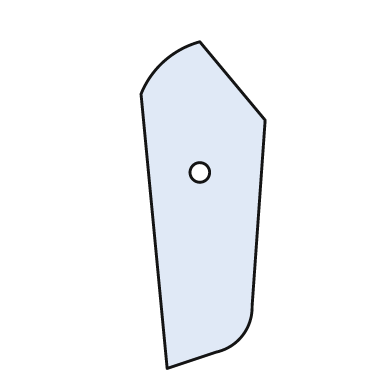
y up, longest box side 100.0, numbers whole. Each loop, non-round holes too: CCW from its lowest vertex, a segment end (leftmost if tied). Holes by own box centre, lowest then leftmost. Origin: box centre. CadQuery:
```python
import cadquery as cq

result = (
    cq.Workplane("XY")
    .moveTo(-11.0, -50.0)
    .lineTo(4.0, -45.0)
    .threePointArc((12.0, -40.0), (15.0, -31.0))
    .lineTo(19.0, 26.0)
    .lineTo(-1.0, 50.0)
    .threePointArc((-12.0, 44.0), (-19.0, 34.0))
    .close()
    .moveTo(-1.0, 10.0)
    .circle(3.0)
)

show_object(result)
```